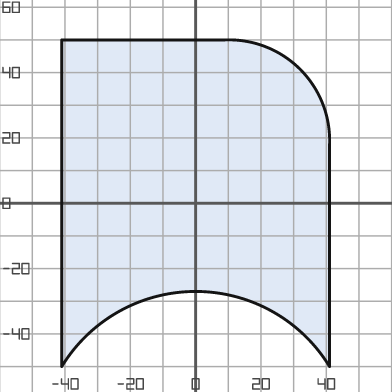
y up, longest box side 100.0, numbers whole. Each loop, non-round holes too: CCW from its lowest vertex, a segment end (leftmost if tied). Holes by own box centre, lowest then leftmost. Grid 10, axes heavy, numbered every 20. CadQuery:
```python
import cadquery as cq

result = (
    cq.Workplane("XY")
    .moveTo(-41.0, -50.0)
    .threePointArc((0.0, -27.0), (41.0, -50.0))
    .lineTo(41.0, 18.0)
    .threePointArc((32.0, 41.0), (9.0, 50.0))
    .lineTo(-41.0, 50.0)
    .close()
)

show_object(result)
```